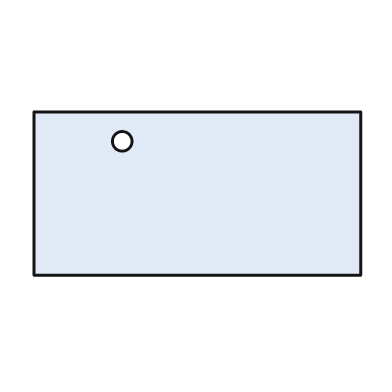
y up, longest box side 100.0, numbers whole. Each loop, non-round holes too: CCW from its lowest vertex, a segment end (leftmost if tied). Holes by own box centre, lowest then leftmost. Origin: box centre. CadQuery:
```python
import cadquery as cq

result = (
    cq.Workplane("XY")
    .moveTo(-50.0, -25.0)
    .lineTo(50.0, -25.0)
    .lineTo(50.0, 25.0)
    .lineTo(-50.0, 25.0)
    .close()
    .moveTo(-23.0, 16.0)
    .circle(3.0)
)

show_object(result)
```